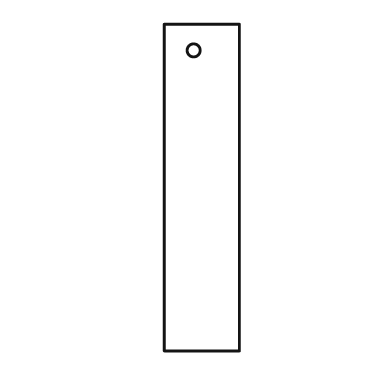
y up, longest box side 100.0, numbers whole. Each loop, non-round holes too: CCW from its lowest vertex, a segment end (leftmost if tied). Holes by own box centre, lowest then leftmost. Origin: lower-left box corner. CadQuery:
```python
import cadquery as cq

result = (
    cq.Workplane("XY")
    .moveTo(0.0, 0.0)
    .lineTo(23.0, 0.0)
    .lineTo(23.0, 100.0)
    .lineTo(0.0, 100.0)
    .close()
    .moveTo(9.0, 92.0)
    .circle(2.0)
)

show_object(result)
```